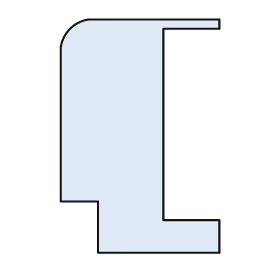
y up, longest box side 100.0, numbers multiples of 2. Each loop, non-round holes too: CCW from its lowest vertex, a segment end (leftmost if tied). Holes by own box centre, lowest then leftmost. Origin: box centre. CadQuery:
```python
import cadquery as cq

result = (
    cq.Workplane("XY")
    .moveTo(-18.0, -50.0)
    .lineTo(34.0, -50.0)
    .lineTo(34.0, -36.0)
    .lineTo(10.0, -36.0)
    .lineTo(10.0, 46.0)
    .lineTo(34.0, 46.0)
    .lineTo(34.0, 50.0)
    .lineTo(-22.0, 50.0)
    .threePointArc((-30.0, 46.0), (-34.0, 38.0))
    .lineTo(-34.0, -28.0)
    .lineTo(-18.0, -28.0)
    .close()
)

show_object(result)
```